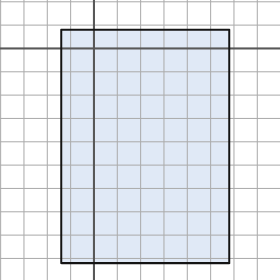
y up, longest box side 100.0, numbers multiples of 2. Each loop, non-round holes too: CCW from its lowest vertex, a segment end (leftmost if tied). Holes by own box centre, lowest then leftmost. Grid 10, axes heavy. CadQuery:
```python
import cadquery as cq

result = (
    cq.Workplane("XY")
    .moveTo(-14.0, -92.0)
    .lineTo(58.0, -92.0)
    .lineTo(58.0, 8.0)
    .lineTo(-14.0, 8.0)
    .close()
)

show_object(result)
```